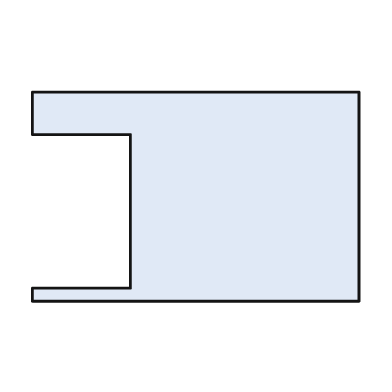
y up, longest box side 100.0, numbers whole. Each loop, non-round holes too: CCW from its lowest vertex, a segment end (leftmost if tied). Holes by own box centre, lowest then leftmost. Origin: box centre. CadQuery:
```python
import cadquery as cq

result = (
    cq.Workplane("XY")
    .moveTo(-50.0, -32.0)
    .lineTo(50.0, -32.0)
    .lineTo(50.0, 32.0)
    .lineTo(-50.0, 32.0)
    .lineTo(-50.0, 19.0)
    .lineTo(-20.0, 19.0)
    .lineTo(-20.0, -28.0)
    .lineTo(-50.0, -28.0)
    .close()
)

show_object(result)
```